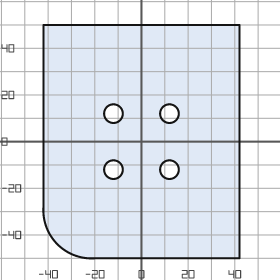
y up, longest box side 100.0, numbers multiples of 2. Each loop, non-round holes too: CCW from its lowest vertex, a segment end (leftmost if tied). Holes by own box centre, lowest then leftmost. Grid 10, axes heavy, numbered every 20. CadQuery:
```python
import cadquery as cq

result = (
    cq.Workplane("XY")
    .moveTo(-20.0, -50.0)
    .lineTo(42.0, -50.0)
    .lineTo(42.0, 50.0)
    .lineTo(-42.0, 50.0)
    .lineTo(-42.0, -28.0)
    .threePointArc((-36.0, -44.0), (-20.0, -50.0))
    .close()
    .moveTo(-12.0, -12.0)
    .circle(4.0)
    .moveTo(12.0, -12.0)
    .circle(4.0)
    .moveTo(-12.0, 12.0)
    .circle(4.0)
    .moveTo(12.0, 12.0)
    .circle(4.0)
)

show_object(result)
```